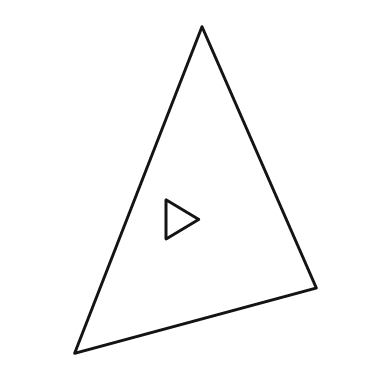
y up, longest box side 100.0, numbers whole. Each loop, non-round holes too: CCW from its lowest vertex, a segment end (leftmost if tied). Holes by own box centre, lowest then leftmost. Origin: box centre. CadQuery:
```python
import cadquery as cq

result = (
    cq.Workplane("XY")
    .moveTo(-37.0, -50.0)
    .lineTo(37.0, -30.0)
    .lineTo(2.0, 50.0)
    .close()
    .moveTo(-9.0, -15.0)
    .lineTo(1.0, -9.0)
    .lineTo(-9.0, -3.0)
    .close()
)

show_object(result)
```